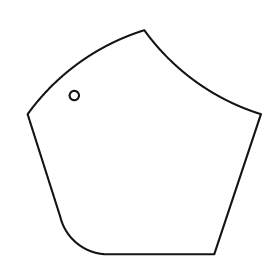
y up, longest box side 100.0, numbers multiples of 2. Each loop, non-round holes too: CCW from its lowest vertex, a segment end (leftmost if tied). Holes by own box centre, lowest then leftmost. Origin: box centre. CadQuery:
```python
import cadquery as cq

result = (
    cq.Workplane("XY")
    .moveTo(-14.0, -48.0)
    .lineTo(30.0, -48.0)
    .lineTo(50.0, 12.0)
    .threePointArc((22.0, 26.0), (0.0, 48.0))
    .threePointArc((-28.0, 34.0), (-50.0, 12.0))
    .lineTo(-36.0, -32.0)
    .threePointArc((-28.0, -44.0), (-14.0, -48.0))
    .close()
    .moveTo(-30.0, 20.0)
    .circle(2.0)
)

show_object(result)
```